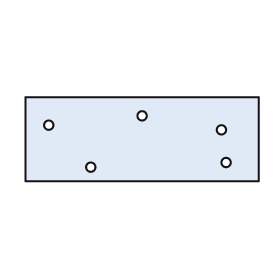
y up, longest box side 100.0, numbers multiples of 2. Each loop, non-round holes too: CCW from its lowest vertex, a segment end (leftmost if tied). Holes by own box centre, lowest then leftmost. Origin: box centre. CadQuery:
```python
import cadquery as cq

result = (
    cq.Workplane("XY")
    .moveTo(-50.0, -18.0)
    .lineTo(50.0, -18.0)
    .lineTo(50.0, 18.0)
    .lineTo(-50.0, 18.0)
    .close()
    .moveTo(-22.0, -12.0)
    .circle(2.0)
    .moveTo(36.0, -10.0)
    .circle(2.0)
    .moveTo(34.0, 4.0)
    .circle(2.0)
    .moveTo(-40.0, 6.0)
    .circle(2.0)
    .moveTo(0.0, 10.0)
    .circle(2.0)
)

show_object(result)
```